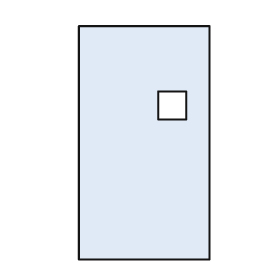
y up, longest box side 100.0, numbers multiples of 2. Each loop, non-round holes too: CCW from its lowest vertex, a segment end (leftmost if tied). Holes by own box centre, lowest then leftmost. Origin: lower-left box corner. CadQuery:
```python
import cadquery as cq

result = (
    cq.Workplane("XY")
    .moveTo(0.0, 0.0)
    .lineTo(56.0, 0.0)
    .lineTo(56.0, 100.0)
    .lineTo(0.0, 100.0)
    .close()
    .moveTo(34.0, 60.0)
    .lineTo(46.0, 60.0)
    .lineTo(46.0, 72.0)
    .lineTo(34.0, 72.0)
    .close()
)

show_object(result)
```